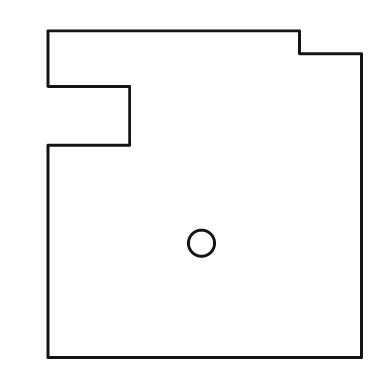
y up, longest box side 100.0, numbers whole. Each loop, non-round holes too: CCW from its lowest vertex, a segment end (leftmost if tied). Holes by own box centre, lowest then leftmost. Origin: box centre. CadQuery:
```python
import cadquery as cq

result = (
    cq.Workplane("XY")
    .moveTo(-48.0, -50.0)
    .lineTo(48.0, -50.0)
    .lineTo(48.0, 43.0)
    .lineTo(29.0, 43.0)
    .lineTo(29.0, 50.0)
    .lineTo(-48.0, 50.0)
    .lineTo(-48.0, 33.0)
    .lineTo(-23.0, 33.0)
    .lineTo(-23.0, 15.0)
    .lineTo(-48.0, 15.0)
    .close()
    .moveTo(-1.0, -15.0)
    .circle(4.0)
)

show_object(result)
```